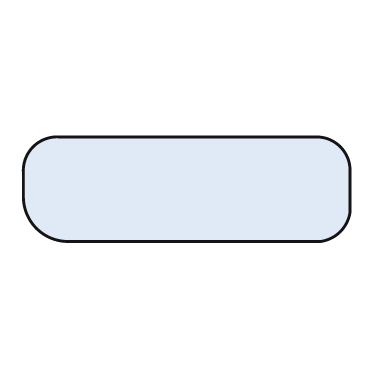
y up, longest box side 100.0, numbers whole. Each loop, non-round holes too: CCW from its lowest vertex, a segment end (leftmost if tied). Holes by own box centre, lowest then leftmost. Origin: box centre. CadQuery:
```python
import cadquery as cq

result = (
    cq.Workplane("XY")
    .moveTo(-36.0, -16.0)
    .lineTo(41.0, -16.0)
    .threePointArc((47.0, -13.0), (50.0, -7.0))
    .lineTo(50.0, 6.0)
    .threePointArc((47.0, 13.0), (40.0, 16.0))
    .lineTo(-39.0, 16.0)
    .threePointArc((-47.0, 13.0), (-50.0, 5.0))
    .lineTo(-50.0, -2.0)
    .threePointArc((-46.0, -12.0), (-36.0, -16.0))
    .close()
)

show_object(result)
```